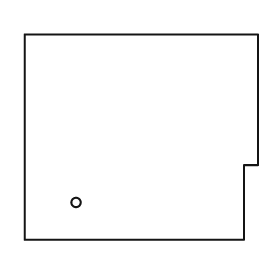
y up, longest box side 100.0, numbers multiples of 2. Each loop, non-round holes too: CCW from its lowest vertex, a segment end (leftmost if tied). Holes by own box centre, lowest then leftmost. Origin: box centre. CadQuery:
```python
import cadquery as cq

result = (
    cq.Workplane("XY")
    .moveTo(-50.0, -44.0)
    .lineTo(44.0, -44.0)
    .lineTo(44.0, -12.0)
    .lineTo(50.0, -12.0)
    .lineTo(50.0, 44.0)
    .lineTo(-50.0, 44.0)
    .close()
    .moveTo(-28.0, -28.0)
    .circle(2.0)
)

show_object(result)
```